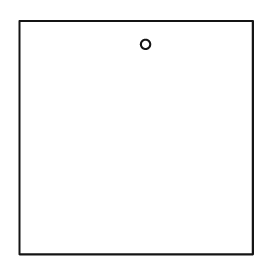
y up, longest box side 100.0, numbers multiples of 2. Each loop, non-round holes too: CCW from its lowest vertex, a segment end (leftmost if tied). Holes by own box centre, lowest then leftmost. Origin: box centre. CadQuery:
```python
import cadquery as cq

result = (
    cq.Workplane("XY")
    .moveTo(-50.0, -50.0)
    .lineTo(50.0, -50.0)
    .lineTo(50.0, 50.0)
    .lineTo(-50.0, 50.0)
    .close()
    .moveTo(4.0, 40.0)
    .circle(2.0)
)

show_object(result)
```